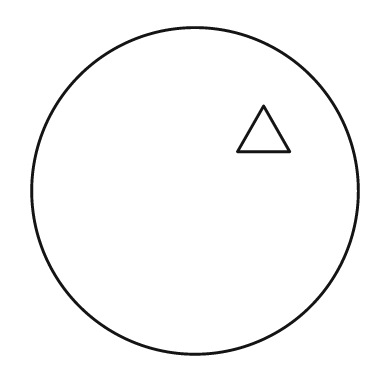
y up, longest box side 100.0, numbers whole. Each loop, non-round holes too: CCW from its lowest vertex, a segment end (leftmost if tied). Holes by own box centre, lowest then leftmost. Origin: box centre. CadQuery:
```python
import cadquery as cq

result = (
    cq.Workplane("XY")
    .moveTo(0.0, 0.0)
    .circle(50.0)
    .moveTo(13.0, 12.0)
    .lineTo(29.0, 12.0)
    .lineTo(21.0, 26.0)
    .close()
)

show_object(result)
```